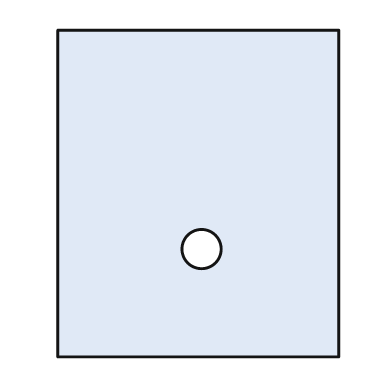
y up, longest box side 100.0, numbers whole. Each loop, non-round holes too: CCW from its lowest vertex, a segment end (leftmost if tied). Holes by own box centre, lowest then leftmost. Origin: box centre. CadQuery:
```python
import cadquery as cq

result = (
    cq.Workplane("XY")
    .moveTo(-43.0, -50.0)
    .lineTo(43.0, -50.0)
    .lineTo(43.0, 50.0)
    .lineTo(-43.0, 50.0)
    .close()
    .moveTo(1.0, -17.0)
    .circle(6.0)
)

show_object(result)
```